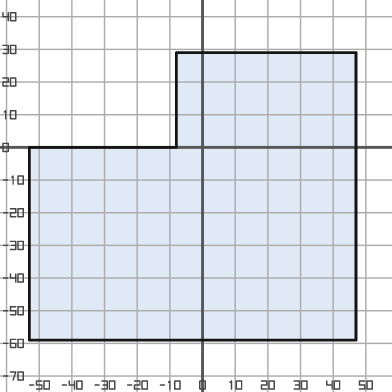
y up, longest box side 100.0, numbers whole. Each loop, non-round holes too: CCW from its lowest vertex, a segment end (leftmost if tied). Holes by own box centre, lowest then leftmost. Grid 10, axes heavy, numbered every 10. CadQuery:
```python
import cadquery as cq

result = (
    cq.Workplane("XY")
    .moveTo(-53.0, -59.0)
    .lineTo(47.0, -59.0)
    .lineTo(47.0, 29.0)
    .lineTo(-8.0, 29.0)
    .lineTo(-8.0, 0.0)
    .lineTo(-53.0, 0.0)
    .close()
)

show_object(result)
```